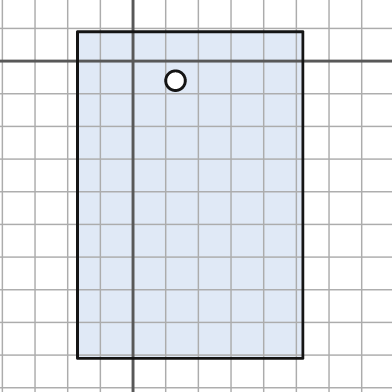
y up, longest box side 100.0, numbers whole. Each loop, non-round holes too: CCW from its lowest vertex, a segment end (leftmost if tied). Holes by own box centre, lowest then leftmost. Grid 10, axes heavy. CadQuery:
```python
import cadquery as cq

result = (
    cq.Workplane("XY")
    .moveTo(-17.0, -91.0)
    .lineTo(52.0, -91.0)
    .lineTo(52.0, 9.0)
    .lineTo(-17.0, 9.0)
    .close()
    .moveTo(13.0, -6.0)
    .circle(3.0)
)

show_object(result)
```